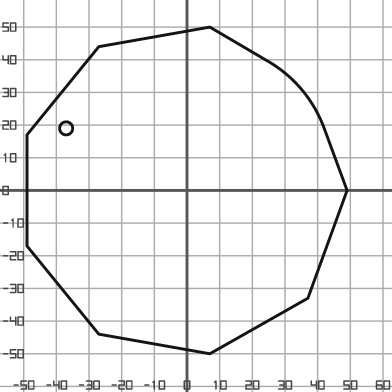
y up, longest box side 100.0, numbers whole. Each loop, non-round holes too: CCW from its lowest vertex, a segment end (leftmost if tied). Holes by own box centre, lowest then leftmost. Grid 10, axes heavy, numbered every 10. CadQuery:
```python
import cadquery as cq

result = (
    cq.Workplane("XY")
    .moveTo(7.0, -50.0)
    .lineTo(37.0, -33.0)
    .lineTo(49.0, 0.0)
    .lineTo(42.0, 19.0)
    .threePointArc((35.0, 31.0), (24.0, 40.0))
    .lineTo(7.0, 50.0)
    .lineTo(-27.0, 44.0)
    .lineTo(-49.0, 17.0)
    .lineTo(-49.0, -17.0)
    .lineTo(-27.0, -44.0)
    .close()
    .moveTo(-37.0, 19.0)
    .circle(2.0)
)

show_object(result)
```